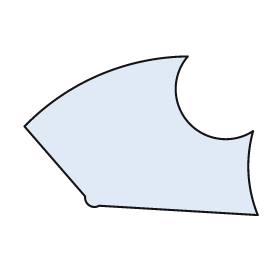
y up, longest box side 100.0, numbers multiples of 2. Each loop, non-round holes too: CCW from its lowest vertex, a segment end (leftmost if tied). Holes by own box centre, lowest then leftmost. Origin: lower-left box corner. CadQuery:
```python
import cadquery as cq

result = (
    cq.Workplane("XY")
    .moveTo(100.0, 0.0)
    .threePointArc((96.0, 18.0), (98.0, 36.0))
    .threePointArc((70.0, 40.0), (70.0, 68.0))
    .threePointArc((32.0, 60.0), (0.0, 38.0))
    .lineTo(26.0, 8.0)
    .threePointArc((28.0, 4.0), (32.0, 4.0))
    .close()
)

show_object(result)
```